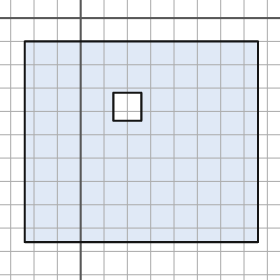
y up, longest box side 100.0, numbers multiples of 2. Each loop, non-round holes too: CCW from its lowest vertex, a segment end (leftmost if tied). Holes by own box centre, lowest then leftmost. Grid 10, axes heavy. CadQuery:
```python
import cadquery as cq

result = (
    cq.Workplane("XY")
    .moveTo(-24.0, -96.0)
    .lineTo(76.0, -96.0)
    .lineTo(76.0, -10.0)
    .lineTo(-24.0, -10.0)
    .close()
    .moveTo(14.0, -44.0)
    .lineTo(26.0, -44.0)
    .lineTo(26.0, -32.0)
    .lineTo(14.0, -32.0)
    .close()
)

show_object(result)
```